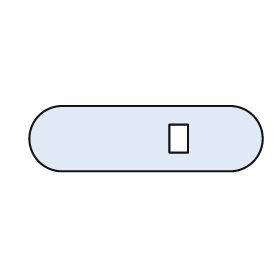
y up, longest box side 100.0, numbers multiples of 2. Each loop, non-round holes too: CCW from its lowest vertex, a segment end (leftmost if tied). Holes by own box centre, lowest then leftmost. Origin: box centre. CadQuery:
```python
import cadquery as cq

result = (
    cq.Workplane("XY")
    .moveTo(-36.0, -14.0)
    .lineTo(36.0, -14.0)
    .threePointArc((50.0, 0.0), (36.0, 14.0))
    .lineTo(-36.0, 14.0)
    .threePointArc((-50.0, 0.0), (-36.0, -14.0))
    .close()
    .moveTo(10.0, -6.0)
    .lineTo(18.0, -6.0)
    .lineTo(18.0, 6.0)
    .lineTo(10.0, 6.0)
    .close()
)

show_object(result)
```